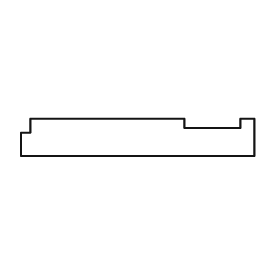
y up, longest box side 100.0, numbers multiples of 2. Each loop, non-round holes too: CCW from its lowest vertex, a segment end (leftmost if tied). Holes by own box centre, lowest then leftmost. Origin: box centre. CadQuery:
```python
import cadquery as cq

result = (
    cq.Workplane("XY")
    .moveTo(-50.0, -8.0)
    .lineTo(50.0, -8.0)
    .lineTo(50.0, 8.0)
    .lineTo(44.0, 8.0)
    .lineTo(44.0, 4.0)
    .lineTo(20.0, 4.0)
    .lineTo(20.0, 8.0)
    .lineTo(-46.0, 8.0)
    .lineTo(-46.0, 2.0)
    .lineTo(-50.0, 2.0)
    .close()
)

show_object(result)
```